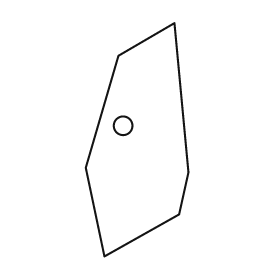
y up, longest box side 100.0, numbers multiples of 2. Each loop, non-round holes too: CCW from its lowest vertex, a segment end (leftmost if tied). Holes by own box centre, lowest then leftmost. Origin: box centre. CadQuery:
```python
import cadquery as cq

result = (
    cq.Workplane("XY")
    .moveTo(-14.0, -50.0)
    .lineTo(18.0, -32.0)
    .lineTo(22.0, -14.0)
    .lineTo(16.0, 50.0)
    .lineTo(-8.0, 36.0)
    .lineTo(-22.0, -12.0)
    .close()
    .moveTo(-6.0, 6.0)
    .circle(4.0)
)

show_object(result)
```